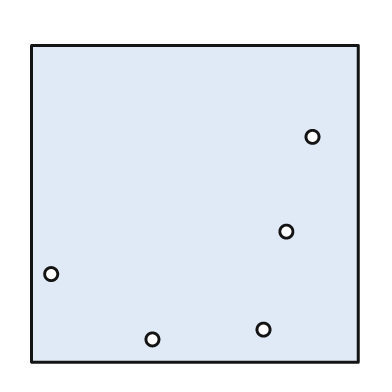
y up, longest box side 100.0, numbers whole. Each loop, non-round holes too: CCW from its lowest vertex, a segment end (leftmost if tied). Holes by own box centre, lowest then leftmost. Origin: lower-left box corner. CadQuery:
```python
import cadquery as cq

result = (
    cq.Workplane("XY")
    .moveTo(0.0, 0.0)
    .lineTo(100.0, 0.0)
    .lineTo(100.0, 97.0)
    .lineTo(0.0, 97.0)
    .close()
    .moveTo(37.0, 7.0)
    .circle(2.0)
    .moveTo(71.0, 10.0)
    .circle(2.0)
    .moveTo(6.0, 27.0)
    .circle(2.0)
    .moveTo(78.0, 40.0)
    .circle(2.0)
    .moveTo(86.0, 69.0)
    .circle(2.0)
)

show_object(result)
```